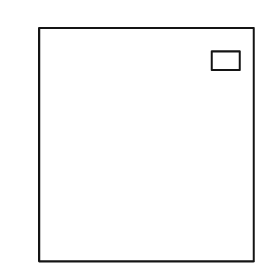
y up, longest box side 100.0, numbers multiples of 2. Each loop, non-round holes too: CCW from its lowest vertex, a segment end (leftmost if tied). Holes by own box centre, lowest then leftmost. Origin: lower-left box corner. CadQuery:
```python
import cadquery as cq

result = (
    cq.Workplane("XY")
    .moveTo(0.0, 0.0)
    .lineTo(92.0, 0.0)
    .lineTo(92.0, 100.0)
    .lineTo(0.0, 100.0)
    .close()
    .moveTo(74.0, 82.0)
    .lineTo(86.0, 82.0)
    .lineTo(86.0, 90.0)
    .lineTo(74.0, 90.0)
    .close()
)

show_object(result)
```